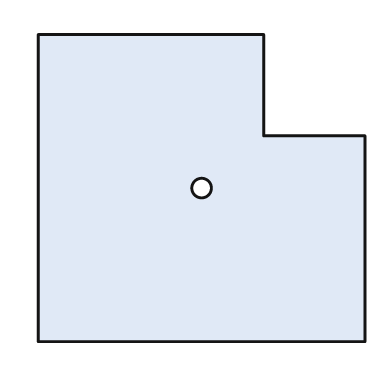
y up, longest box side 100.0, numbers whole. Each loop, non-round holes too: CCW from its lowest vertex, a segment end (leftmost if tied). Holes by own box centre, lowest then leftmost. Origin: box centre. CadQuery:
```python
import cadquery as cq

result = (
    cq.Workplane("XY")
    .moveTo(-50.0, -47.0)
    .lineTo(50.0, -47.0)
    .lineTo(50.0, 16.0)
    .lineTo(19.0, 16.0)
    .lineTo(19.0, 47.0)
    .lineTo(-50.0, 47.0)
    .close()
    .moveTo(0.0, 0.0)
    .circle(3.0)
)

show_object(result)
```